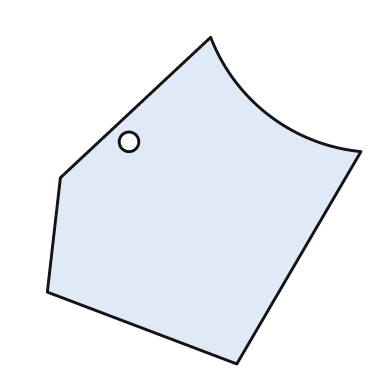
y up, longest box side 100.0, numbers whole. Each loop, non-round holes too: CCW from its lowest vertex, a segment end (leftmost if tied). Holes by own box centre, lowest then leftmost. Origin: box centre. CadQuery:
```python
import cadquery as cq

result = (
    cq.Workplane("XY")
    .moveTo(10.0, -50.0)
    .lineTo(48.0, 15.0)
    .threePointArc((20.0, 26.0), (2.0, 50.0))
    .lineTo(-44.0, 7.0)
    .lineTo(-48.0, -28.0)
    .close()
    .moveTo(-23.0, 18.0)
    .circle(3.0)
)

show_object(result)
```